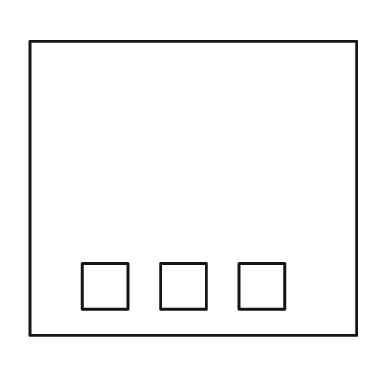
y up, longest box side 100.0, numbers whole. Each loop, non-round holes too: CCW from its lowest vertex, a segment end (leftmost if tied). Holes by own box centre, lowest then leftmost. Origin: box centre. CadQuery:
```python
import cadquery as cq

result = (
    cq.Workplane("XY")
    .moveTo(-50.0, -45.0)
    .lineTo(50.0, -45.0)
    .lineTo(50.0, 45.0)
    .lineTo(-50.0, 45.0)
    .close()
    .moveTo(-34.0, -37.0)
    .lineTo(-20.0, -37.0)
    .lineTo(-20.0, -23.0)
    .lineTo(-34.0, -23.0)
    .close()
    .moveTo(-10.0, -37.0)
    .lineTo(4.0, -37.0)
    .lineTo(4.0, -23.0)
    .lineTo(-10.0, -23.0)
    .close()
    .moveTo(14.0, -37.0)
    .lineTo(28.0, -37.0)
    .lineTo(28.0, -23.0)
    .lineTo(14.0, -23.0)
    .close()
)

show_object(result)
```